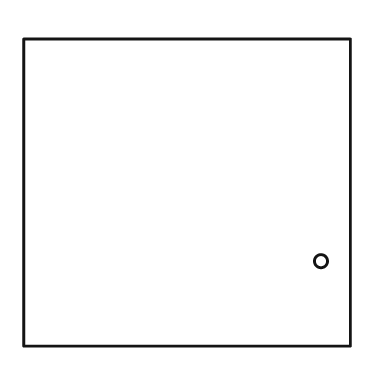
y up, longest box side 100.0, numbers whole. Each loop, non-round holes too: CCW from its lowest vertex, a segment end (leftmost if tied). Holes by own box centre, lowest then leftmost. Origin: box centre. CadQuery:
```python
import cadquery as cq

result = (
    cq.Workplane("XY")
    .moveTo(-50.0, -47.0)
    .lineTo(50.0, -47.0)
    .lineTo(50.0, 47.0)
    .lineTo(-50.0, 47.0)
    .close()
    .moveTo(41.0, -21.0)
    .circle(2.0)
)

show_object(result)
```